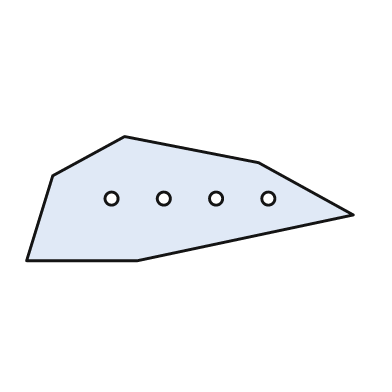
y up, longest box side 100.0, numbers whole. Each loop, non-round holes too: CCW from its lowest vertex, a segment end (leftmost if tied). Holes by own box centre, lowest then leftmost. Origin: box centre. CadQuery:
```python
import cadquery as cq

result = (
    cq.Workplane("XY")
    .moveTo(-50.0, -19.0)
    .lineTo(-16.0, -19.0)
    .lineTo(50.0, -5.0)
    .lineTo(21.0, 11.0)
    .lineTo(-20.0, 19.0)
    .lineTo(-42.0, 7.0)
    .close()
    .moveTo(-24.0, 0.0)
    .circle(2.0)
    .moveTo(-8.0, 0.0)
    .circle(2.0)
    .moveTo(8.0, 0.0)
    .circle(2.0)
    .moveTo(24.0, 0.0)
    .circle(2.0)
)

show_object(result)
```